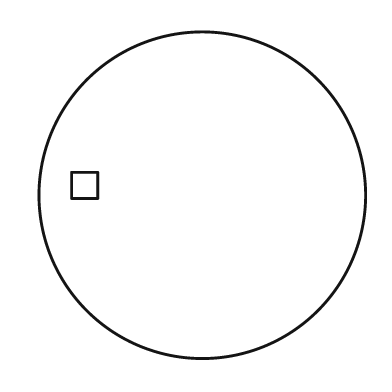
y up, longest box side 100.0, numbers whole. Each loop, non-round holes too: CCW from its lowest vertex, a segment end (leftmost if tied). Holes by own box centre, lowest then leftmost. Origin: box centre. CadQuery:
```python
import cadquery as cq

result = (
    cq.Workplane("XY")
    .moveTo(0.0, 0.0)
    .circle(50.0)
    .moveTo(-40.0, -1.0)
    .lineTo(-32.0, -1.0)
    .lineTo(-32.0, 7.0)
    .lineTo(-40.0, 7.0)
    .close()
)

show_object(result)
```